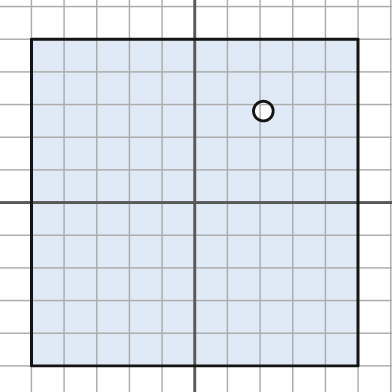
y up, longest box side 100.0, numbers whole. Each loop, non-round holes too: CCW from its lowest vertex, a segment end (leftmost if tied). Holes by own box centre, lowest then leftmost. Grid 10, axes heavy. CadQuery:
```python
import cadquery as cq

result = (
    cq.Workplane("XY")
    .moveTo(-50.0, -50.0)
    .lineTo(50.0, -50.0)
    .lineTo(50.0, 50.0)
    .lineTo(-50.0, 50.0)
    .close()
    .moveTo(21.0, 28.0)
    .circle(3.0)
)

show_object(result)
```